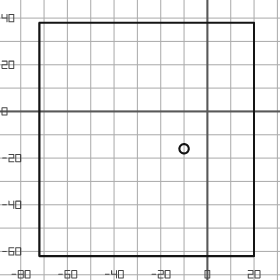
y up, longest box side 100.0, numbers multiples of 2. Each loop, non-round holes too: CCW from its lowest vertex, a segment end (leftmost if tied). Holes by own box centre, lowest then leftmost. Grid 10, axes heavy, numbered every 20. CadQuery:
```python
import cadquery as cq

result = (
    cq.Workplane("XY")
    .moveTo(-72.0, -62.0)
    .lineTo(20.0, -62.0)
    .lineTo(20.0, 38.0)
    .lineTo(-72.0, 38.0)
    .close()
    .moveTo(-10.0, -16.0)
    .circle(2.0)
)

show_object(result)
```